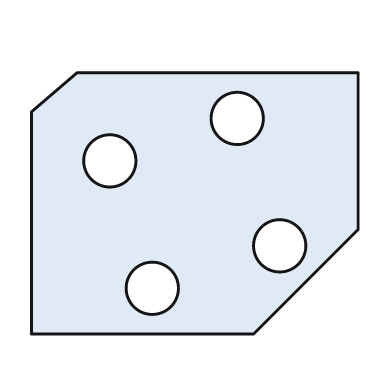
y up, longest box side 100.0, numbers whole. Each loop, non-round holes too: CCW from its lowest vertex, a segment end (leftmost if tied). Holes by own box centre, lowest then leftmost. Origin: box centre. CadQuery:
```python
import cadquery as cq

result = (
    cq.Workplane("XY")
    .moveTo(-50.0, -40.0)
    .lineTo(18.0, -40.0)
    .lineTo(50.0, -8.0)
    .lineTo(50.0, 40.0)
    .lineTo(-36.0, 40.0)
    .lineTo(-50.0, 28.0)
    .close()
    .moveTo(-13.0, -26.0)
    .circle(8.0)
    .moveTo(26.0, -13.0)
    .circle(8.0)
    .moveTo(-26.0, 13.0)
    .circle(8.0)
    .moveTo(13.0, 26.0)
    .circle(8.0)
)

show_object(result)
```